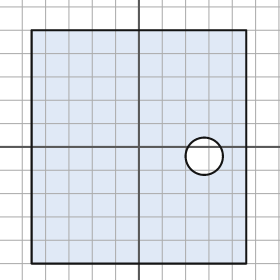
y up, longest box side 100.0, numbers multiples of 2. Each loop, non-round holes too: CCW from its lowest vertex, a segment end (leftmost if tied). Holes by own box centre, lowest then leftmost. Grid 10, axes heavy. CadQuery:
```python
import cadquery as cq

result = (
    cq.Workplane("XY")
    .moveTo(-46.0, -50.0)
    .lineTo(46.0, -50.0)
    .lineTo(46.0, 50.0)
    .lineTo(-46.0, 50.0)
    .close()
    .moveTo(28.0, -4.0)
    .circle(8.0)
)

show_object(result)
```